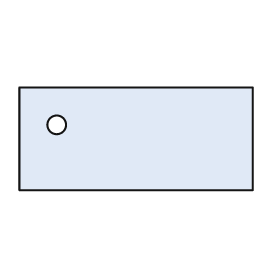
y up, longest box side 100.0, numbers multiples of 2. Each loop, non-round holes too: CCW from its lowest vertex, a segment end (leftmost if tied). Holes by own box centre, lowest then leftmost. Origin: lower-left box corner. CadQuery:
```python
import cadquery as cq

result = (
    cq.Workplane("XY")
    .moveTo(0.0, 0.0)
    .lineTo(100.0, 0.0)
    .lineTo(100.0, 44.0)
    .lineTo(0.0, 44.0)
    .close()
    .moveTo(16.0, 28.0)
    .circle(4.0)
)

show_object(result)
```